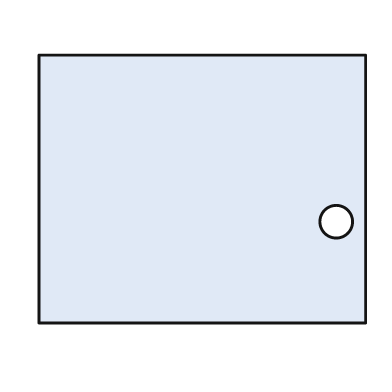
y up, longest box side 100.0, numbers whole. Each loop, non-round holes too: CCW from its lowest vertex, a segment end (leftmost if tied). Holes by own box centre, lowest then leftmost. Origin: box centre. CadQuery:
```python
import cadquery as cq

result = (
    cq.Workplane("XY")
    .moveTo(-50.0, -41.0)
    .lineTo(50.0, -41.0)
    .lineTo(50.0, 41.0)
    .lineTo(-50.0, 41.0)
    .close()
    .moveTo(41.0, -10.0)
    .circle(5.0)
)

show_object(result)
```